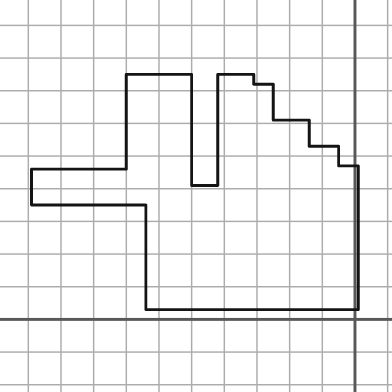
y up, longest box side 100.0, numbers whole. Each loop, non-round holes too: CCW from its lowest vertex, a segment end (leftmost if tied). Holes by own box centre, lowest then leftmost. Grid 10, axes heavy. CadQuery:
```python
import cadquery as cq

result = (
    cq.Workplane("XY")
    .moveTo(-64.0, 3.0)
    .lineTo(1.0, 3.0)
    .lineTo(1.0, 47.0)
    .lineTo(-5.0, 47.0)
    .lineTo(-5.0, 53.0)
    .lineTo(-14.0, 53.0)
    .lineTo(-14.0, 61.0)
    .lineTo(-25.0, 61.0)
    .lineTo(-25.0, 72.0)
    .lineTo(-31.0, 72.0)
    .lineTo(-31.0, 75.0)
    .lineTo(-42.0, 75.0)
    .lineTo(-42.0, 41.0)
    .lineTo(-50.0, 41.0)
    .lineTo(-50.0, 75.0)
    .lineTo(-70.0, 75.0)
    .lineTo(-70.0, 46.0)
    .lineTo(-99.0, 46.0)
    .lineTo(-99.0, 35.0)
    .lineTo(-64.0, 35.0)
    .close()
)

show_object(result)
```